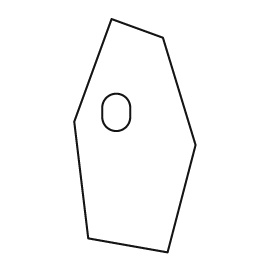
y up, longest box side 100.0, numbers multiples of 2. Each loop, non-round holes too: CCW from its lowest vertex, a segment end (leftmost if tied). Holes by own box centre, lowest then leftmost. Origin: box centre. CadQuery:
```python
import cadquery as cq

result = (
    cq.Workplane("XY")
    .moveTo(14.0, -50.0)
    .lineTo(26.0, -4.0)
    .lineTo(12.0, 42.0)
    .lineTo(-10.0, 50.0)
    .lineTo(-26.0, 6.0)
    .lineTo(-20.0, -44.0)
    .close()
    .moveTo(-14.0, 8.0)
    .threePointArc((-8.0, 2.0), (-2.0, 8.0))
    .lineTo(-2.0, 12.0)
    .threePointArc((-8.0, 18.0), (-14.0, 12.0))
    .close()
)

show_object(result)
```